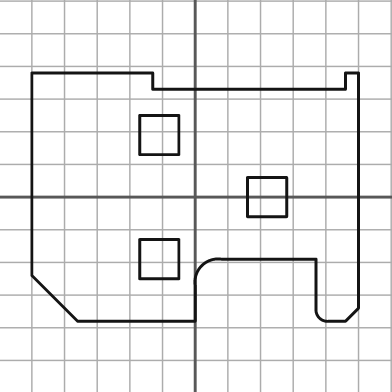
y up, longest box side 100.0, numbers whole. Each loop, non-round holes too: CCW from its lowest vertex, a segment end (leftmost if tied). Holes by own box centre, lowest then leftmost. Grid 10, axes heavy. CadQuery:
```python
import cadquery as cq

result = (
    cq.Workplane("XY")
    .moveTo(-36.0, -38.0)
    .lineTo(0.0, -38.0)
    .lineTo(0.0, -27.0)
    .threePointArc((2.0, -21.0), (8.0, -19.0))
    .lineTo(37.0, -19.0)
    .lineTo(37.0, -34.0)
    .threePointArc((38.0, -37.0), (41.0, -38.0))
    .lineTo(46.0, -38.0)
    .lineTo(50.0, -34.0)
    .lineTo(50.0, 38.0)
    .lineTo(46.0, 38.0)
    .lineTo(46.0, 33.0)
    .lineTo(-13.0, 33.0)
    .lineTo(-13.0, 38.0)
    .lineTo(-50.0, 38.0)
    .lineTo(-50.0, -24.0)
    .close()
    .moveTo(-17.0, -25.0)
    .lineTo(-5.0, -25.0)
    .lineTo(-5.0, -13.0)
    .lineTo(-17.0, -13.0)
    .close()
    .moveTo(16.0, -6.0)
    .lineTo(28.0, -6.0)
    .lineTo(28.0, 6.0)
    .lineTo(16.0, 6.0)
    .close()
    .moveTo(-17.0, 13.0)
    .lineTo(-5.0, 13.0)
    .lineTo(-5.0, 25.0)
    .lineTo(-17.0, 25.0)
    .close()
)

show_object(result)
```